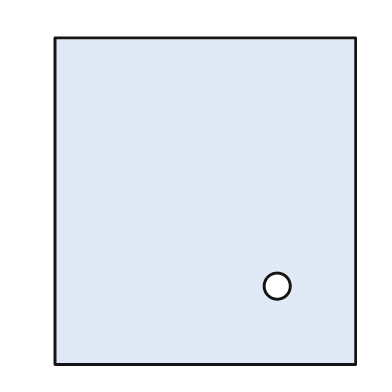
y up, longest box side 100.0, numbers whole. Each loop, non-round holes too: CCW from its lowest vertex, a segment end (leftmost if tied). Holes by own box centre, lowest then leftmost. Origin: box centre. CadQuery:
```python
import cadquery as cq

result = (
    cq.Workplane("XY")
    .moveTo(-46.0, -50.0)
    .lineTo(46.0, -50.0)
    .lineTo(46.0, 50.0)
    .lineTo(-46.0, 50.0)
    .close()
    .moveTo(22.0, -26.0)
    .circle(4.0)
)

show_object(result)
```